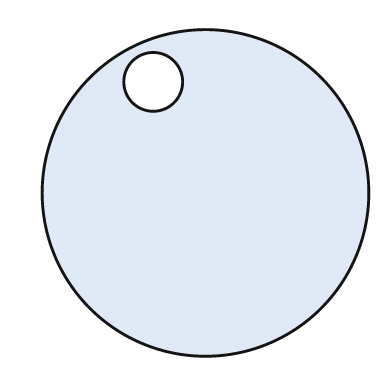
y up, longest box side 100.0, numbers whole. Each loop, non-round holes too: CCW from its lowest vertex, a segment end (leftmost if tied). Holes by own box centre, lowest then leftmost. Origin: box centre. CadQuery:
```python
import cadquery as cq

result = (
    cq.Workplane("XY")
    .moveTo(0.0, 0.0)
    .circle(50.0)
    .moveTo(-16.0, 34.0)
    .circle(9.0)
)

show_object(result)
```